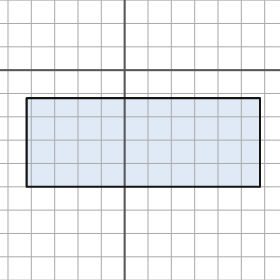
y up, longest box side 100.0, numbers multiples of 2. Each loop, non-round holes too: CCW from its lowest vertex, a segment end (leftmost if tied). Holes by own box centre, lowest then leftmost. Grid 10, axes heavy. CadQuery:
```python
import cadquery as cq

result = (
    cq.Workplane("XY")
    .moveTo(-42.0, -50.0)
    .lineTo(58.0, -50.0)
    .lineTo(58.0, -12.0)
    .lineTo(-42.0, -12.0)
    .close()
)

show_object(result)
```